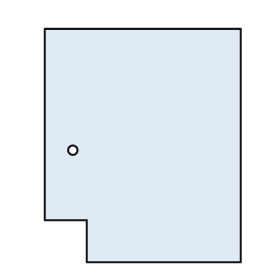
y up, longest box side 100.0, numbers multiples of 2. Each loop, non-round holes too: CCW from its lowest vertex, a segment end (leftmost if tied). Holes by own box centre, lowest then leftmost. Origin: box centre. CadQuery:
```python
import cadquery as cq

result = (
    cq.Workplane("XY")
    .moveTo(-24.0, -50.0)
    .lineTo(42.0, -50.0)
    .lineTo(42.0, 50.0)
    .lineTo(-42.0, 50.0)
    .lineTo(-42.0, -32.0)
    .lineTo(-24.0, -32.0)
    .close()
    .moveTo(-30.0, -2.0)
    .circle(2.0)
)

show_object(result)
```